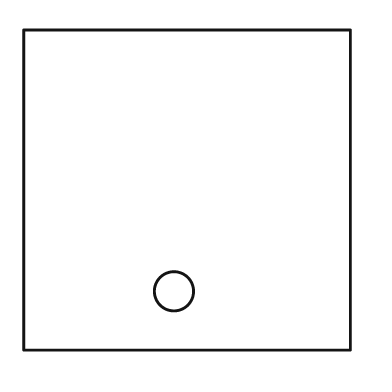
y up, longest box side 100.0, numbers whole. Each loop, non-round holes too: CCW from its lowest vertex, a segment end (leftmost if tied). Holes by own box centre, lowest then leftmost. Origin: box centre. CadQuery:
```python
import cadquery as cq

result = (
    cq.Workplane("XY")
    .moveTo(-50.0, -49.0)
    .lineTo(50.0, -49.0)
    .lineTo(50.0, 49.0)
    .lineTo(-50.0, 49.0)
    .close()
    .moveTo(-4.0, -31.0)
    .circle(6.0)
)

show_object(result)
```